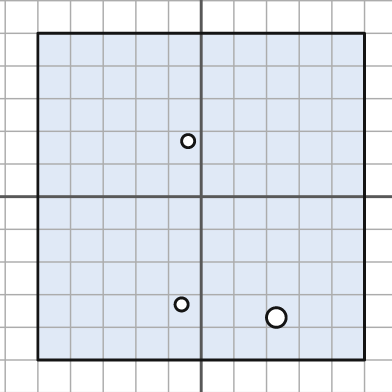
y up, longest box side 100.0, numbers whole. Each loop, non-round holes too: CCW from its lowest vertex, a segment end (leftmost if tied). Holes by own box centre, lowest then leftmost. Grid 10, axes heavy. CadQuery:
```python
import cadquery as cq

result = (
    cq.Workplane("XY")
    .moveTo(-50.0, -50.0)
    .lineTo(50.0, -50.0)
    .lineTo(50.0, 50.0)
    .lineTo(-50.0, 50.0)
    .close()
    .moveTo(23.0, -37.0)
    .circle(3.0)
    .moveTo(-6.0, -33.0)
    .circle(2.0)
    .moveTo(-4.0, 17.0)
    .circle(2.0)
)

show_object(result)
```